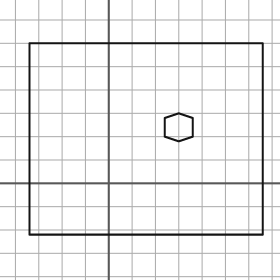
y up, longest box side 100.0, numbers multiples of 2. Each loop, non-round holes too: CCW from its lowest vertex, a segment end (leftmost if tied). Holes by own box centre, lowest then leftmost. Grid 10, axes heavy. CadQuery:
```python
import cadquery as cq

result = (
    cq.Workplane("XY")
    .moveTo(-34.0, -22.0)
    .lineTo(66.0, -22.0)
    .lineTo(66.0, 60.0)
    .lineTo(-34.0, 60.0)
    .close()
    .moveTo(30.0, 18.0)
    .lineTo(36.0, 20.0)
    .lineTo(36.0, 28.0)
    .lineTo(30.0, 30.0)
    .lineTo(24.0, 28.0)
    .lineTo(24.0, 20.0)
    .close()
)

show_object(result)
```